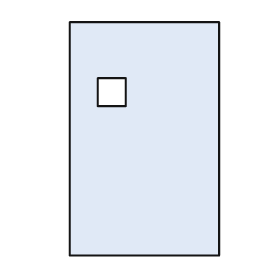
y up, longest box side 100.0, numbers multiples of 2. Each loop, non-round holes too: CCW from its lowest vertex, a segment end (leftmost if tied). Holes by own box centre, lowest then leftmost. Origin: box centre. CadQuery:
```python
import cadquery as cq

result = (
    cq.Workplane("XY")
    .moveTo(-32.0, -50.0)
    .lineTo(32.0, -50.0)
    .lineTo(32.0, 50.0)
    .lineTo(-32.0, 50.0)
    .close()
    .moveTo(-20.0, 14.0)
    .lineTo(-8.0, 14.0)
    .lineTo(-8.0, 26.0)
    .lineTo(-20.0, 26.0)
    .close()
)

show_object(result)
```